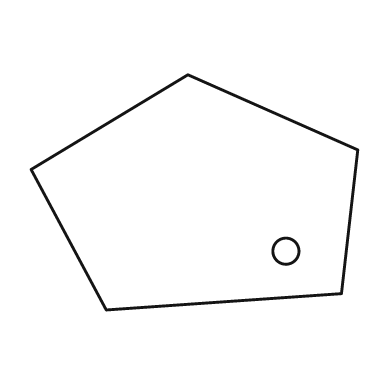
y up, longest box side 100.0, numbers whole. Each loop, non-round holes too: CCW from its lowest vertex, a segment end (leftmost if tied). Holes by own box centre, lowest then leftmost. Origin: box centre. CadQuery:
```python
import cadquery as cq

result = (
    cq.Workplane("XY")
    .moveTo(-27.0, -36.0)
    .lineTo(45.0, -31.0)
    .lineTo(50.0, 13.0)
    .lineTo(-2.0, 36.0)
    .lineTo(-50.0, 7.0)
    .close()
    .moveTo(28.0, -18.0)
    .circle(4.0)
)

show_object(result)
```